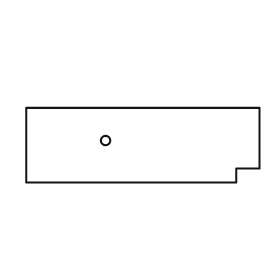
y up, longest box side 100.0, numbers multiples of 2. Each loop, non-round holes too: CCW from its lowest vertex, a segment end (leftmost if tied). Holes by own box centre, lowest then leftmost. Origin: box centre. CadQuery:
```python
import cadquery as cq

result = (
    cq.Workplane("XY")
    .moveTo(-50.0, -16.0)
    .lineTo(40.0, -16.0)
    .lineTo(40.0, -10.0)
    .lineTo(50.0, -10.0)
    .lineTo(50.0, 16.0)
    .lineTo(-50.0, 16.0)
    .close()
    .moveTo(-16.0, 2.0)
    .circle(2.0)
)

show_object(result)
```